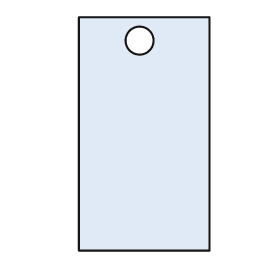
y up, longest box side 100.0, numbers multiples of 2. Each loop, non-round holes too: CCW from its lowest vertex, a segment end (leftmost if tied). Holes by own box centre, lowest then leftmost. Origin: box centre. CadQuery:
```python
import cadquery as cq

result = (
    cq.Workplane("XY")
    .moveTo(-28.0, -50.0)
    .lineTo(28.0, -50.0)
    .lineTo(28.0, 50.0)
    .lineTo(-28.0, 50.0)
    .close()
    .moveTo(-2.0, 40.0)
    .circle(6.0)
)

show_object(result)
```